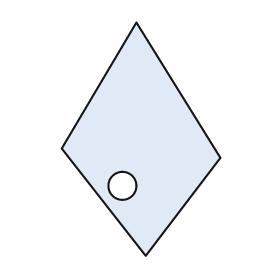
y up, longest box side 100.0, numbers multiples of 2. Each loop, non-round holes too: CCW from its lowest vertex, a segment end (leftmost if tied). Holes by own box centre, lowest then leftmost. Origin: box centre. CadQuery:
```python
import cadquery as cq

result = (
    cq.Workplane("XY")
    .moveTo(2.0, -50.0)
    .lineTo(34.0, -8.0)
    .lineTo(-2.0, 50.0)
    .lineTo(-34.0, -4.0)
    .close()
    .moveTo(-8.0, -20.0)
    .circle(6.0)
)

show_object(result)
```